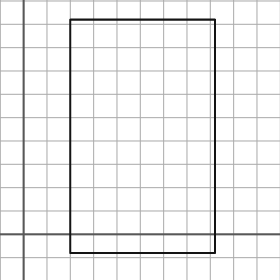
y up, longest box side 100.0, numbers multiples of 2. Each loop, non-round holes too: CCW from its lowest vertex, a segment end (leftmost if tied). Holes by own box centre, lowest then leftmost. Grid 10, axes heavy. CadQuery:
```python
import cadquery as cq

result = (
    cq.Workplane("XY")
    .moveTo(20.0, -8.0)
    .lineTo(82.0, -8.0)
    .lineTo(82.0, 92.0)
    .lineTo(20.0, 92.0)
    .close()
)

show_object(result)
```